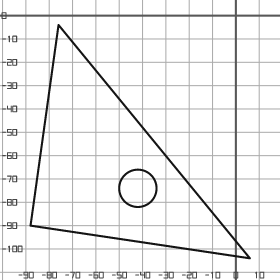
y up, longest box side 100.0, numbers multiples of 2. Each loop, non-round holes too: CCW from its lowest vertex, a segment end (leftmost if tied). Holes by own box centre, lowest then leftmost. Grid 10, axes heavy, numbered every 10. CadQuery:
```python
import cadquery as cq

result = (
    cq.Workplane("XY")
    .moveTo(6.0, -104.0)
    .lineTo(-76.0, -4.0)
    .lineTo(-88.0, -90.0)
    .close()
    .moveTo(-42.0, -74.0)
    .circle(8.0)
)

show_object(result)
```